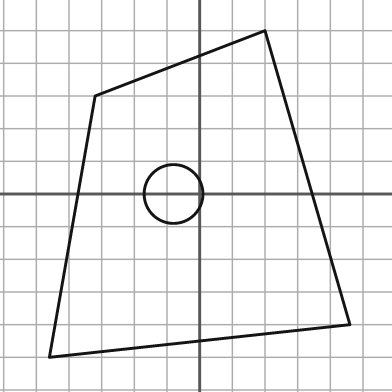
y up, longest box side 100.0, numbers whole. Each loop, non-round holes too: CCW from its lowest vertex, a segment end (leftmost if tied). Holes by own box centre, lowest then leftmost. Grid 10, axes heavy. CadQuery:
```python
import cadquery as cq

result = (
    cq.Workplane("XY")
    .moveTo(-46.0, -50.0)
    .lineTo(46.0, -40.0)
    .lineTo(20.0, 50.0)
    .lineTo(-32.0, 30.0)
    .close()
    .moveTo(-8.0, 0.0)
    .circle(9.0)
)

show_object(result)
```